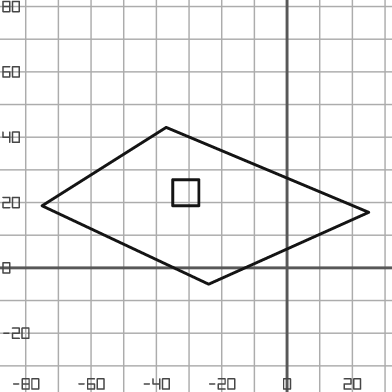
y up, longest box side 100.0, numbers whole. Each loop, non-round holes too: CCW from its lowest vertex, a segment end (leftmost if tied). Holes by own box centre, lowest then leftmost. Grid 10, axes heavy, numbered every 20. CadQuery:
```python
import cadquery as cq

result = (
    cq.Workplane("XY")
    .moveTo(-24.0, -5.0)
    .lineTo(25.0, 17.0)
    .lineTo(-37.0, 43.0)
    .lineTo(-75.0, 19.0)
    .close()
    .moveTo(-35.0, 19.0)
    .lineTo(-27.0, 19.0)
    .lineTo(-27.0, 27.0)
    .lineTo(-35.0, 27.0)
    .close()
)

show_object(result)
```